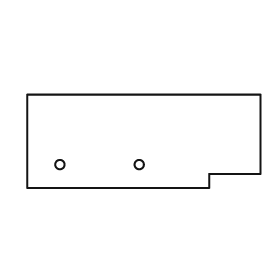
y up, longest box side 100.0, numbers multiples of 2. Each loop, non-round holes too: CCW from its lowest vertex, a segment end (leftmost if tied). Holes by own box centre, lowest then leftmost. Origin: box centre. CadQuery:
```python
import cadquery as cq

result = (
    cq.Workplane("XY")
    .moveTo(-50.0, -20.0)
    .lineTo(28.0, -20.0)
    .lineTo(28.0, -14.0)
    .lineTo(50.0, -14.0)
    .lineTo(50.0, 20.0)
    .lineTo(-50.0, 20.0)
    .close()
    .moveTo(-36.0, -10.0)
    .circle(2.0)
    .moveTo(-2.0, -10.0)
    .circle(2.0)
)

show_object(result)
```